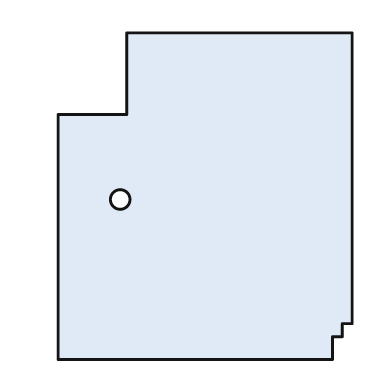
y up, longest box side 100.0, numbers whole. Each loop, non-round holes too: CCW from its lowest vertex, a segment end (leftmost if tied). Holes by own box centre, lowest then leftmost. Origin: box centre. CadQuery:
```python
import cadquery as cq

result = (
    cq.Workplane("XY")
    .moveTo(-45.0, -50.0)
    .lineTo(39.0, -50.0)
    .lineTo(39.0, -43.0)
    .lineTo(42.0, -43.0)
    .lineTo(42.0, -39.0)
    .lineTo(45.0, -39.0)
    .lineTo(45.0, 50.0)
    .lineTo(-24.0, 50.0)
    .lineTo(-24.0, 25.0)
    .lineTo(-45.0, 25.0)
    .close()
    .moveTo(-26.0, -1.0)
    .circle(3.0)
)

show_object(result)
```